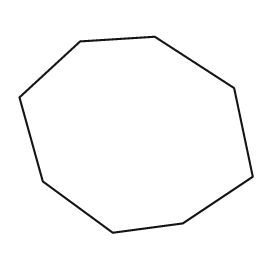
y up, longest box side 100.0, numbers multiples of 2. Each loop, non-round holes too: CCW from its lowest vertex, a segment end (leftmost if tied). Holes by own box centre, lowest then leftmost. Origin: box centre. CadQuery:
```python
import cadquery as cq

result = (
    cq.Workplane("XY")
    .moveTo(-10.0, -42.0)
    .lineTo(20.0, -38.0)
    .lineTo(50.0, -18.0)
    .lineTo(42.0, 20.0)
    .lineTo(8.0, 42.0)
    .lineTo(-24.0, 40.0)
    .lineTo(-50.0, 16.0)
    .lineTo(-40.0, -20.0)
    .close()
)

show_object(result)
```